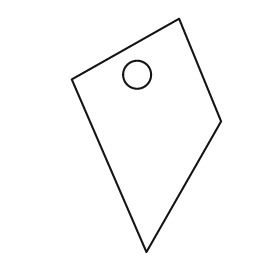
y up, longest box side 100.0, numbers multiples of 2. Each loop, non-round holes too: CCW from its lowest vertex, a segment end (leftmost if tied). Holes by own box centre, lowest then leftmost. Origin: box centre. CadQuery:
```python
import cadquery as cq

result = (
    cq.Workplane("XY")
    .moveTo(0.0, -50.0)
    .lineTo(32.0, 6.0)
    .lineTo(14.0, 50.0)
    .lineTo(-32.0, 24.0)
    .close()
    .moveTo(-4.0, 26.0)
    .circle(6.0)
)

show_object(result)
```